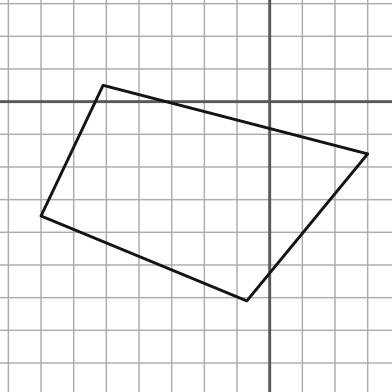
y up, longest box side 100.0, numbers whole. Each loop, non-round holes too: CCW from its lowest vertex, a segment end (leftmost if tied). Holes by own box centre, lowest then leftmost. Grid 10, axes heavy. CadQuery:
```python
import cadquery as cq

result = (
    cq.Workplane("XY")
    .moveTo(-7.0, -61.0)
    .lineTo(30.0, -16.0)
    .lineTo(-51.0, 5.0)
    .lineTo(-70.0, -35.0)
    .close()
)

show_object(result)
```